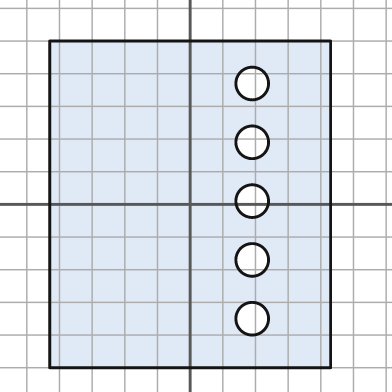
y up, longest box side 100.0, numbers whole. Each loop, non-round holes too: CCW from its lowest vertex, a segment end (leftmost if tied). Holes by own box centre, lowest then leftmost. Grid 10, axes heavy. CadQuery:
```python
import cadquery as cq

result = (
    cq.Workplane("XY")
    .moveTo(-43.0, -50.0)
    .lineTo(43.0, -50.0)
    .lineTo(43.0, 50.0)
    .lineTo(-43.0, 50.0)
    .close()
    .moveTo(19.0, -35.0)
    .circle(5.0)
    .moveTo(19.0, -17.0)
    .circle(5.0)
    .moveTo(19.0, 1.0)
    .circle(5.0)
    .moveTo(19.0, 19.0)
    .circle(5.0)
    .moveTo(19.0, 37.0)
    .circle(5.0)
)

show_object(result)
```